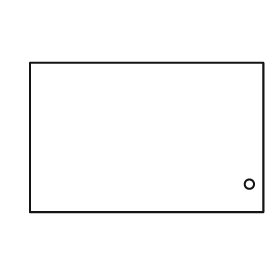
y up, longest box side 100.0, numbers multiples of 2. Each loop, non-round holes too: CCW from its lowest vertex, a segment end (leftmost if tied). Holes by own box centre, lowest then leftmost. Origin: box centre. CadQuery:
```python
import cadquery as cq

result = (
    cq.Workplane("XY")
    .moveTo(-50.0, -32.0)
    .lineTo(50.0, -32.0)
    .lineTo(50.0, 32.0)
    .lineTo(-50.0, 32.0)
    .close()
    .moveTo(44.0, -20.0)
    .circle(2.0)
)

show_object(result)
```